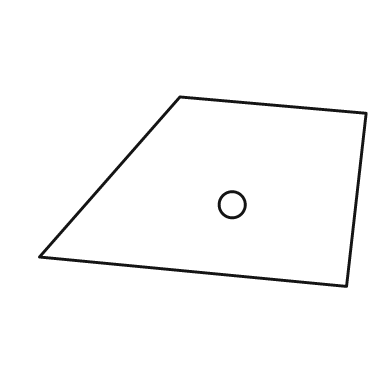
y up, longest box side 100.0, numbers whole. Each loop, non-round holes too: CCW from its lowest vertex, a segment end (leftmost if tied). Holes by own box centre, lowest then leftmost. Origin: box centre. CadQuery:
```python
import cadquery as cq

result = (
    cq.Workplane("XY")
    .moveTo(44.0, -29.0)
    .lineTo(50.0, 24.0)
    .lineTo(-7.0, 29.0)
    .lineTo(-50.0, -20.0)
    .close()
    .moveTo(9.0, -4.0)
    .circle(4.0)
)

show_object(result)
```